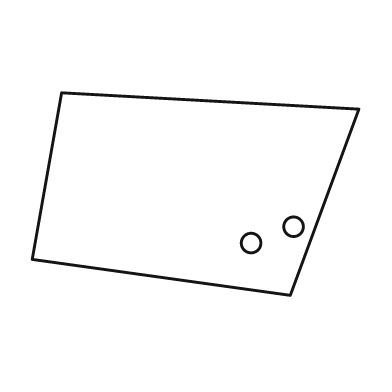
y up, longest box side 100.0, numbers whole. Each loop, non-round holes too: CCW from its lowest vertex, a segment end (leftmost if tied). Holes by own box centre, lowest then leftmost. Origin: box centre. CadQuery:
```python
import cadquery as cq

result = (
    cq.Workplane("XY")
    .moveTo(29.0, -31.0)
    .lineTo(50.0, 26.0)
    .lineTo(-41.0, 31.0)
    .lineTo(-50.0, -20.0)
    .close()
    .moveTo(17.0, -15.0)
    .circle(3.0)
    .moveTo(30.0, -10.0)
    .circle(3.0)
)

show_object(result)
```